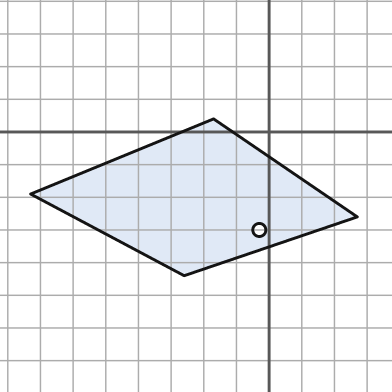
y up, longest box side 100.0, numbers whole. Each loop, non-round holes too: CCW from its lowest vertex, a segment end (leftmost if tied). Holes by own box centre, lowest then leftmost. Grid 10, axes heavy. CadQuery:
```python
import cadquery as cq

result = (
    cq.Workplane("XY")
    .moveTo(-26.0, -44.0)
    .lineTo(27.0, -26.0)
    .lineTo(-17.0, 4.0)
    .lineTo(-73.0, -19.0)
    .close()
    .moveTo(-3.0, -30.0)
    .circle(2.0)
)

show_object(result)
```